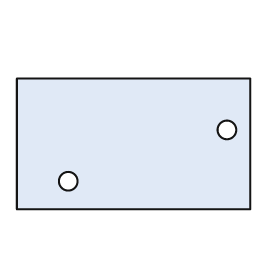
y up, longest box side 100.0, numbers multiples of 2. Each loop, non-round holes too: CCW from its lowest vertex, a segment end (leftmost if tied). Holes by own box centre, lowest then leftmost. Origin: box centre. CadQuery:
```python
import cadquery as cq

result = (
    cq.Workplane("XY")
    .moveTo(-50.0, -28.0)
    .lineTo(50.0, -28.0)
    .lineTo(50.0, 28.0)
    .lineTo(-50.0, 28.0)
    .close()
    .moveTo(-28.0, -16.0)
    .circle(4.0)
    .moveTo(40.0, 6.0)
    .circle(4.0)
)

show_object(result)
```